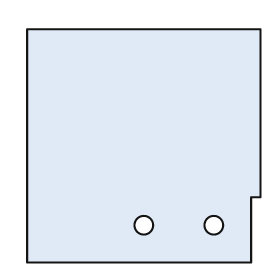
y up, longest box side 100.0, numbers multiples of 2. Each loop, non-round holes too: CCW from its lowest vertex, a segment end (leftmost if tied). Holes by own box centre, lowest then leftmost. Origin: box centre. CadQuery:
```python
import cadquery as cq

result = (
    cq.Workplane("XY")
    .moveTo(-50.0, -50.0)
    .lineTo(46.0, -50.0)
    .lineTo(46.0, -22.0)
    .lineTo(50.0, -22.0)
    .lineTo(50.0, 50.0)
    .lineTo(-50.0, 50.0)
    .close()
    .moveTo(0.0, -34.0)
    .circle(4.0)
    .moveTo(30.0, -34.0)
    .circle(4.0)
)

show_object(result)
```